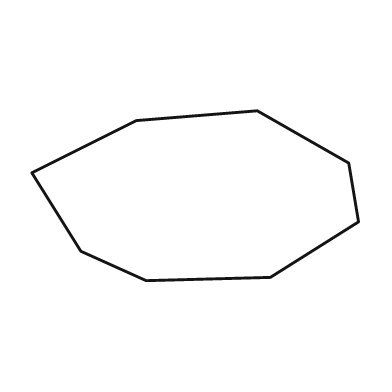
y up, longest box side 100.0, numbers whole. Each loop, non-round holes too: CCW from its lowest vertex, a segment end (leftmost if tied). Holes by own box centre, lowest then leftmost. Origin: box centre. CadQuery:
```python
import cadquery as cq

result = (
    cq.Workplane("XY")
    .moveTo(-15.0, -26.0)
    .lineTo(23.0, -25.0)
    .lineTo(50.0, -8.0)
    .lineTo(47.0, 10.0)
    .lineTo(19.0, 26.0)
    .lineTo(-18.0, 23.0)
    .lineTo(-50.0, 7.0)
    .lineTo(-35.0, -17.0)
    .close()
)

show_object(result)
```